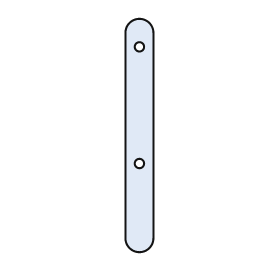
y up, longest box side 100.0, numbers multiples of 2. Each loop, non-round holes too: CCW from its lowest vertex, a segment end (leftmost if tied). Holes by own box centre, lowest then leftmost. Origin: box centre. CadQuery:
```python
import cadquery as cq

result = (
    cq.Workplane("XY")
    .moveTo(-6.0, -44.0)
    .threePointArc((0.0, -50.0), (6.0, -44.0))
    .lineTo(6.0, 44.0)
    .threePointArc((0.0, 50.0), (-6.0, 44.0))
    .close()
    .moveTo(0.0, -12.0)
    .circle(2.0)
    .moveTo(0.0, 38.0)
    .circle(2.0)
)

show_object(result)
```